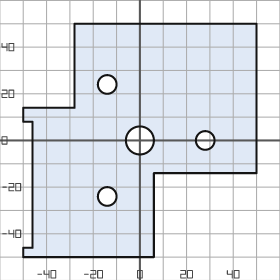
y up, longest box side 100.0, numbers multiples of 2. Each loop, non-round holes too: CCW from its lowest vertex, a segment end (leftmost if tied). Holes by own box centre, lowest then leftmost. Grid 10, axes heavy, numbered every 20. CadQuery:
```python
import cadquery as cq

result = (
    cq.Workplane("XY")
    .moveTo(-50.0, -50.0)
    .lineTo(6.0, -50.0)
    .lineTo(6.0, -14.0)
    .lineTo(50.0, -14.0)
    .lineTo(50.0, 50.0)
    .lineTo(-28.0, 50.0)
    .lineTo(-28.0, 14.0)
    .lineTo(-50.0, 14.0)
    .lineTo(-50.0, 8.0)
    .lineTo(-46.0, 8.0)
    .lineTo(-46.0, -46.0)
    .lineTo(-50.0, -46.0)
    .close()
    .moveTo(-14.0, -24.0)
    .circle(4.0)
    .moveTo(0.0, 0.0)
    .circle(6.0)
    .moveTo(28.0, 0.0)
    .circle(4.0)
    .moveTo(-14.0, 24.0)
    .circle(4.0)
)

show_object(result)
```